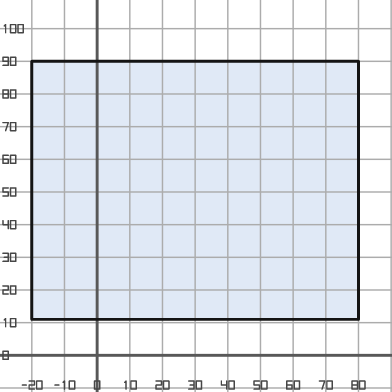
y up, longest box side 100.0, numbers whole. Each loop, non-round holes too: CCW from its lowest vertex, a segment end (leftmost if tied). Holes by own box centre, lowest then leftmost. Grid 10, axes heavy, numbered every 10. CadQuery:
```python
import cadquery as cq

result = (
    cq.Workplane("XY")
    .moveTo(-20.0, 11.0)
    .lineTo(80.0, 11.0)
    .lineTo(80.0, 90.0)
    .lineTo(-20.0, 90.0)
    .close()
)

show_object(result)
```